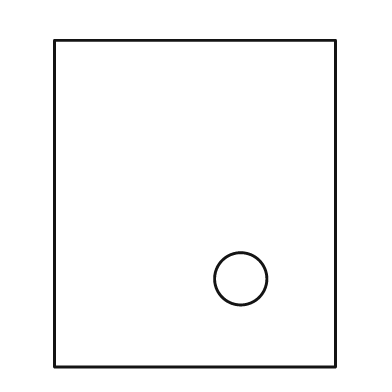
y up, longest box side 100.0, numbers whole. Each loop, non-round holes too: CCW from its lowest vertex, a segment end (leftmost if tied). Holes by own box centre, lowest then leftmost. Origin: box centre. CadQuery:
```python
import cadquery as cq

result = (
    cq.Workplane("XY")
    .moveTo(-43.0, -50.0)
    .lineTo(43.0, -50.0)
    .lineTo(43.0, 50.0)
    .lineTo(-43.0, 50.0)
    .close()
    .moveTo(14.0, -23.0)
    .circle(8.0)
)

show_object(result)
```